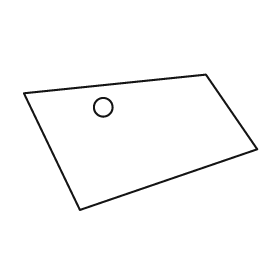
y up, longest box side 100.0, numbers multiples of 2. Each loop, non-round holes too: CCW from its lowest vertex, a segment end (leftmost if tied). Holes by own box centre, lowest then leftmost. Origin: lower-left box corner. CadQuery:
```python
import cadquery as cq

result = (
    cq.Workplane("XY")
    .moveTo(24.0, 0.0)
    .lineTo(100.0, 26.0)
    .lineTo(78.0, 58.0)
    .lineTo(0.0, 50.0)
    .close()
    .moveTo(34.0, 44.0)
    .circle(4.0)
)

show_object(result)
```